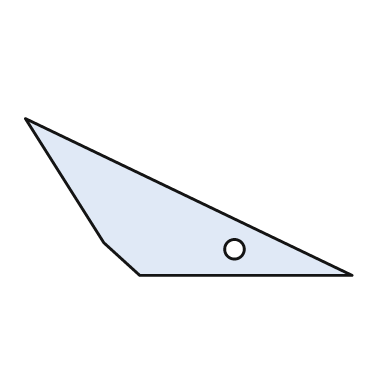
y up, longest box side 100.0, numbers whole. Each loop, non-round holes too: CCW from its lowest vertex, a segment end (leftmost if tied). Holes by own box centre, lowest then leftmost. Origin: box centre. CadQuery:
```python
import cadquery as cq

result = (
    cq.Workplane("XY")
    .moveTo(-15.0, -24.0)
    .lineTo(50.0, -24.0)
    .lineTo(-50.0, 24.0)
    .lineTo(-26.0, -14.0)
    .close()
    .moveTo(14.0, -16.0)
    .circle(3.0)
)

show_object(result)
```